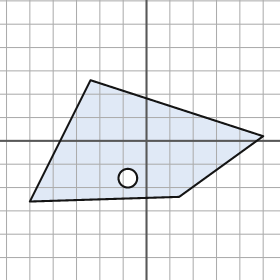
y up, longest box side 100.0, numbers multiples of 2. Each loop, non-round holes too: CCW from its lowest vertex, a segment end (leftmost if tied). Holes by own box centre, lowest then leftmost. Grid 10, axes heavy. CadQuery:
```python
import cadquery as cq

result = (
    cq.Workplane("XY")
    .moveTo(-50.0, -26.0)
    .lineTo(14.0, -24.0)
    .lineTo(50.0, 2.0)
    .lineTo(-24.0, 26.0)
    .close()
    .moveTo(-8.0, -16.0)
    .circle(4.0)
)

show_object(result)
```